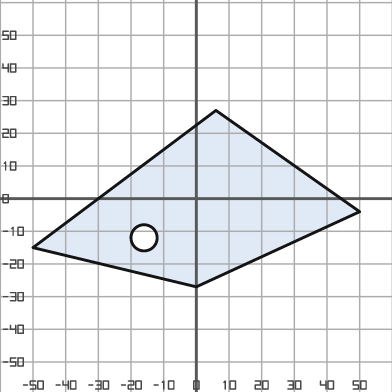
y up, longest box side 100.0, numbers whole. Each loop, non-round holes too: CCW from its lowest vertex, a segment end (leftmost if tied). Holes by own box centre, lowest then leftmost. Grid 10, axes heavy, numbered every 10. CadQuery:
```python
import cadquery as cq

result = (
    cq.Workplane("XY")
    .moveTo(0.0, -27.0)
    .lineTo(50.0, -4.0)
    .lineTo(6.0, 27.0)
    .lineTo(-50.0, -15.0)
    .close()
    .moveTo(-16.0, -12.0)
    .circle(4.0)
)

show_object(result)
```